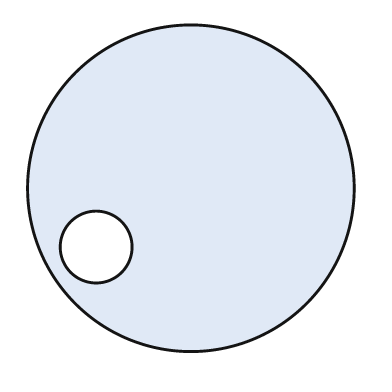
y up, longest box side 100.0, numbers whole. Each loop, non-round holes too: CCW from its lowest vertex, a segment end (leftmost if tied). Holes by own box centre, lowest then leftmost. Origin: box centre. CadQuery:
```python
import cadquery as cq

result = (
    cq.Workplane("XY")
    .moveTo(0.0, 0.0)
    .circle(50.0)
    .moveTo(-29.0, -18.0)
    .circle(11.0)
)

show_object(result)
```